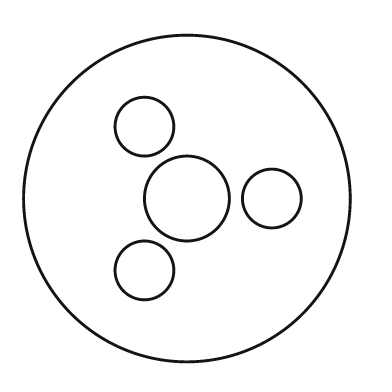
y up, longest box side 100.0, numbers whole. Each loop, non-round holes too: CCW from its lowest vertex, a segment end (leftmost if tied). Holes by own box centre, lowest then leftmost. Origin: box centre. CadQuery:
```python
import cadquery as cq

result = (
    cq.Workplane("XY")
    .moveTo(0.0, 0.0)
    .circle(50.0)
    .moveTo(-13.0, -22.0)
    .circle(9.0)
    .moveTo(0.0, 0.0)
    .circle(13.0)
    .moveTo(26.0, 0.0)
    .circle(9.0)
    .moveTo(-13.0, 22.0)
    .circle(9.0)
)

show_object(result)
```